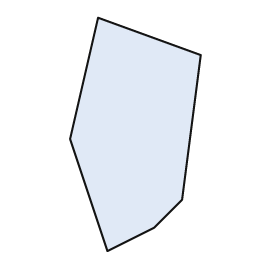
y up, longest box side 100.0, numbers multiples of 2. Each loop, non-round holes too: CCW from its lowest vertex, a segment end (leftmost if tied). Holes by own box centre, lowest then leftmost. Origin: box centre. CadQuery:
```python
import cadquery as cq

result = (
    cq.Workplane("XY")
    .moveTo(-12.0, -50.0)
    .lineTo(8.0, -40.0)
    .lineTo(20.0, -28.0)
    .lineTo(28.0, 34.0)
    .lineTo(-16.0, 50.0)
    .lineTo(-28.0, -2.0)
    .close()
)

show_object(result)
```